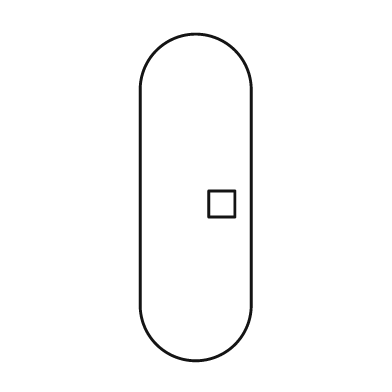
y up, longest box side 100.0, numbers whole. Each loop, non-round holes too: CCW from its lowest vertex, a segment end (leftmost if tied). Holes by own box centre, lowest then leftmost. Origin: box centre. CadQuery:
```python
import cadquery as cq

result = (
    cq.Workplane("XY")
    .moveTo(-17.0, -33.0)
    .threePointArc((0.0, -50.0), (17.0, -33.0))
    .lineTo(17.0, 33.0)
    .threePointArc((0.0, 50.0), (-17.0, 33.0))
    .close()
    .moveTo(4.0, -6.0)
    .lineTo(12.0, -6.0)
    .lineTo(12.0, 2.0)
    .lineTo(4.0, 2.0)
    .close()
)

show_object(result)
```